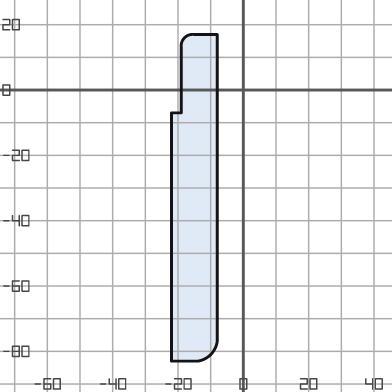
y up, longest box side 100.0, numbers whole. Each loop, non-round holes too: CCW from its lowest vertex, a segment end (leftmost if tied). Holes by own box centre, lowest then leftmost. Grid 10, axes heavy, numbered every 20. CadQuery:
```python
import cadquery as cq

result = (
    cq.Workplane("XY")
    .moveTo(-22.0, -83.0)
    .lineTo(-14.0, -83.0)
    .threePointArc((-10.0, -81.0), (-8.0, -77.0))
    .lineTo(-8.0, 17.0)
    .lineTo(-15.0, 17.0)
    .threePointArc((-18.0, 16.0), (-19.0, 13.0))
    .lineTo(-19.0, -7.0)
    .lineTo(-22.0, -7.0)
    .close()
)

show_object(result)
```